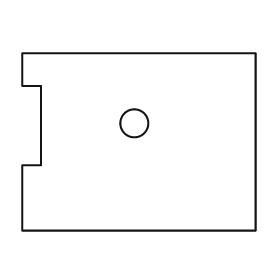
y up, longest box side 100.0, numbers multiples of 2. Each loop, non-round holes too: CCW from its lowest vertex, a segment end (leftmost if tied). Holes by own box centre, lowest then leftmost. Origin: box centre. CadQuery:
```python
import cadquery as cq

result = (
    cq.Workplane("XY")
    .moveTo(-50.0, -38.0)
    .lineTo(50.0, -38.0)
    .lineTo(50.0, 38.0)
    .lineTo(-50.0, 38.0)
    .lineTo(-50.0, 24.0)
    .lineTo(-42.0, 24.0)
    .lineTo(-42.0, -10.0)
    .lineTo(-50.0, -10.0)
    .close()
    .moveTo(-2.0, 8.0)
    .circle(6.0)
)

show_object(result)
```